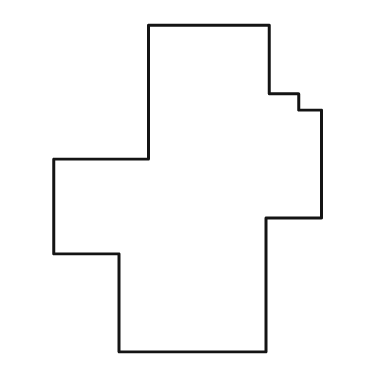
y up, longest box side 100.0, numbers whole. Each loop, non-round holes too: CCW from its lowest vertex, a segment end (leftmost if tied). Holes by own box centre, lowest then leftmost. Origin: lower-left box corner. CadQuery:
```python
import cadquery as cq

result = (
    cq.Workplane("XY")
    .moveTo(20.0, 0.0)
    .lineTo(65.0, 0.0)
    .lineTo(65.0, 41.0)
    .lineTo(82.0, 41.0)
    .lineTo(82.0, 74.0)
    .lineTo(75.0, 74.0)
    .lineTo(75.0, 79.0)
    .lineTo(66.0, 79.0)
    .lineTo(66.0, 100.0)
    .lineTo(29.0, 100.0)
    .lineTo(29.0, 59.0)
    .lineTo(0.0, 59.0)
    .lineTo(0.0, 30.0)
    .lineTo(20.0, 30.0)
    .close()
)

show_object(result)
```